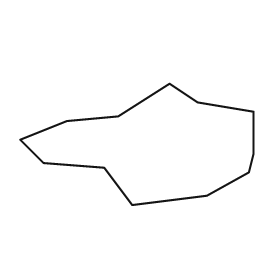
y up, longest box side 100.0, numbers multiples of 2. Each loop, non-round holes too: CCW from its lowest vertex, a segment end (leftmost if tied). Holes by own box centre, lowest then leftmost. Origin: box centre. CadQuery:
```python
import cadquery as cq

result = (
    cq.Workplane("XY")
    .moveTo(-2.0, -26.0)
    .lineTo(30.0, -22.0)
    .lineTo(48.0, -12.0)
    .lineTo(50.0, -4.0)
    .lineTo(50.0, 14.0)
    .lineTo(26.0, 18.0)
    .lineTo(14.0, 26.0)
    .lineTo(-8.0, 12.0)
    .lineTo(-30.0, 10.0)
    .lineTo(-50.0, 2.0)
    .lineTo(-40.0, -8.0)
    .lineTo(-14.0, -10.0)
    .close()
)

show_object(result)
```